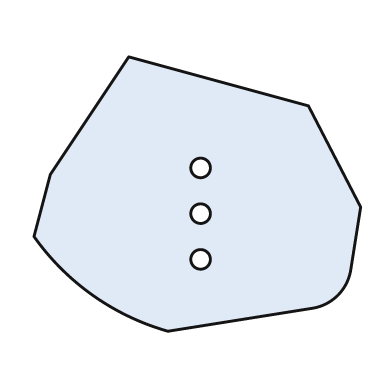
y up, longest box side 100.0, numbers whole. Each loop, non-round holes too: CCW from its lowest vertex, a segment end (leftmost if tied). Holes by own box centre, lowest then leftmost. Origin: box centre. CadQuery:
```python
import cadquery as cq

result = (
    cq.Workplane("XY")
    .moveTo(-9.0, -42.0)
    .lineTo(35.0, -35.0)
    .threePointArc((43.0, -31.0), (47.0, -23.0))
    .lineTo(50.0, -4.0)
    .lineTo(34.0, 27.0)
    .lineTo(-21.0, 42.0)
    .lineTo(-45.0, 6.0)
    .lineTo(-50.0, -13.0)
    .threePointArc((-32.0, -31.0), (-9.0, -42.0))
    .close()
    .moveTo(1.0, -20.0)
    .circle(3.0)
    .moveTo(1.0, -6.0)
    .circle(3.0)
    .moveTo(1.0, 8.0)
    .circle(3.0)
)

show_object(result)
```